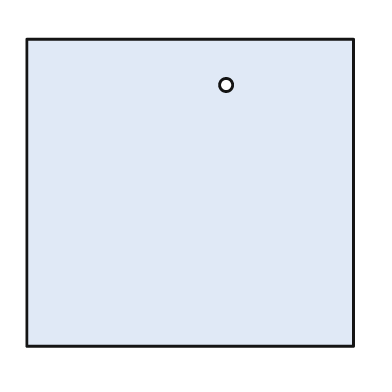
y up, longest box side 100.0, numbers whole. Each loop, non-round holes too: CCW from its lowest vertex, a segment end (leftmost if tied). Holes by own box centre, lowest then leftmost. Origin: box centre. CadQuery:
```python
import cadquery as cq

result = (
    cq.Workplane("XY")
    .moveTo(-50.0, -47.0)
    .lineTo(50.0, -47.0)
    .lineTo(50.0, 47.0)
    .lineTo(-50.0, 47.0)
    .close()
    .moveTo(11.0, 33.0)
    .circle(2.0)
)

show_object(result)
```